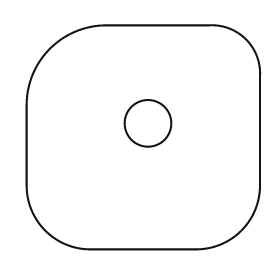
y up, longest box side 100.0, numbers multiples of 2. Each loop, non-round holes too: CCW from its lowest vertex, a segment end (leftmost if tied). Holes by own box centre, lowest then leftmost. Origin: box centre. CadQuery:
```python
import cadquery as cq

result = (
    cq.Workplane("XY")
    .moveTo(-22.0, -48.0)
    .lineTo(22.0, -48.0)
    .threePointArc((42.0, -40.0), (50.0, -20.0))
    .lineTo(50.0, 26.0)
    .threePointArc((44.0, 42.0), (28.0, 48.0))
    .lineTo(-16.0, 48.0)
    .threePointArc((-40.0, 38.0), (-50.0, 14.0))
    .lineTo(-50.0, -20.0)
    .threePointArc((-42.0, -40.0), (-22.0, -48.0))
    .close()
    .moveTo(2.0, 6.0)
    .circle(10.0)
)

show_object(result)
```